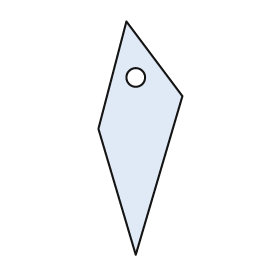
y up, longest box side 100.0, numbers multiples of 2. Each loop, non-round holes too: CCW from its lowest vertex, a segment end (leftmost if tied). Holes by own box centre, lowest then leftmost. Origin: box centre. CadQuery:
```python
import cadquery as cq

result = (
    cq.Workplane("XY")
    .moveTo(-2.0, -50.0)
    .lineTo(18.0, 18.0)
    .lineTo(-6.0, 50.0)
    .lineTo(-18.0, 4.0)
    .close()
    .moveTo(-2.0, 26.0)
    .circle(4.0)
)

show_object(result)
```